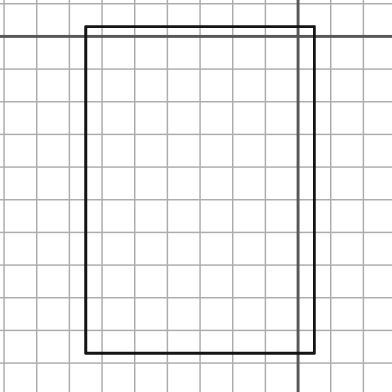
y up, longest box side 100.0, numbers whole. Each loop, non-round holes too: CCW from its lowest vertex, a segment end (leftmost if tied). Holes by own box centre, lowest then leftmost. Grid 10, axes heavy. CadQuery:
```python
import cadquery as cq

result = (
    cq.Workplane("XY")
    .moveTo(-65.0, -97.0)
    .lineTo(5.0, -97.0)
    .lineTo(5.0, 3.0)
    .lineTo(-65.0, 3.0)
    .close()
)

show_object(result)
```